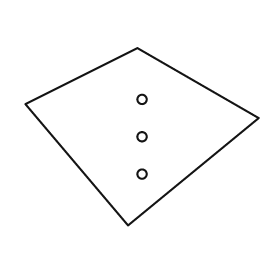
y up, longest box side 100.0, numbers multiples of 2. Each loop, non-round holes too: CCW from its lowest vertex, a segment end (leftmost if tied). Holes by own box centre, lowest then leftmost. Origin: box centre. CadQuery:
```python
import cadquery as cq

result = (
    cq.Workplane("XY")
    .moveTo(-6.0, -38.0)
    .lineTo(50.0, 8.0)
    .lineTo(-2.0, 38.0)
    .lineTo(-50.0, 14.0)
    .close()
    .moveTo(0.0, -16.0)
    .circle(2.0)
    .moveTo(0.0, 0.0)
    .circle(2.0)
    .moveTo(0.0, 16.0)
    .circle(2.0)
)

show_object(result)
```